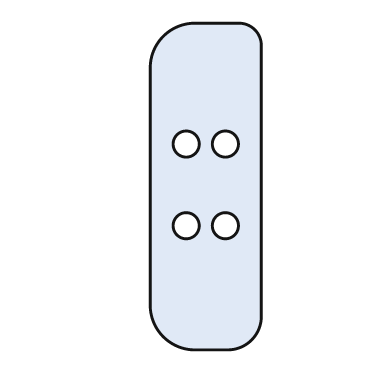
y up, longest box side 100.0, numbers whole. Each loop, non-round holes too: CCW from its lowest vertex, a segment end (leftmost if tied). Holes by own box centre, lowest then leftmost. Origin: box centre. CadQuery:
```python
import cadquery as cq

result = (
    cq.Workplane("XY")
    .moveTo(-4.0, -50.0)
    .lineTo(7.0, -50.0)
    .threePointArc((14.0, -47.0), (17.0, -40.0))
    .lineTo(17.0, 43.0)
    .threePointArc((15.0, 48.0), (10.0, 50.0))
    .lineTo(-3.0, 50.0)
    .threePointArc((-13.0, 46.0), (-17.0, 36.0))
    .lineTo(-17.0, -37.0)
    .threePointArc((-13.0, -46.0), (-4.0, -50.0))
    .close()
    .moveTo(-6.0, -12.0)
    .circle(4.0)
    .moveTo(6.0, -12.0)
    .circle(4.0)
    .moveTo(-6.0, 13.0)
    .circle(4.0)
    .moveTo(6.0, 13.0)
    .circle(4.0)
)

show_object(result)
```